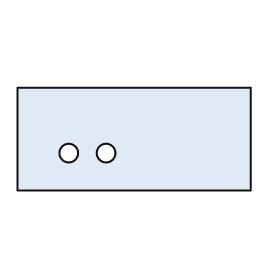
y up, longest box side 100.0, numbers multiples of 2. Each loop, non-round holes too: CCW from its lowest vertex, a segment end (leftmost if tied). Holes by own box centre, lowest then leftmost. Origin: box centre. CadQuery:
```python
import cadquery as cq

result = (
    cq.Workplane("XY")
    .moveTo(-50.0, -22.0)
    .lineTo(50.0, -22.0)
    .lineTo(50.0, 22.0)
    .lineTo(-50.0, 22.0)
    .close()
    .moveTo(-28.0, -6.0)
    .circle(4.0)
    .moveTo(-12.0, -6.0)
    .circle(4.0)
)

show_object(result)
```